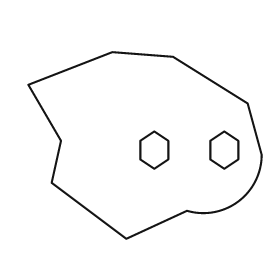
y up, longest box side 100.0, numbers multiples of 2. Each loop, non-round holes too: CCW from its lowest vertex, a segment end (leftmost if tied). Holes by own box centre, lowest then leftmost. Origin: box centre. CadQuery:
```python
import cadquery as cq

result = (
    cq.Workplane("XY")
    .moveTo(-8.0, -40.0)
    .lineTo(18.0, -28.0)
    .threePointArc((40.0, -24.0), (50.0, -4.0))
    .lineTo(44.0, 18.0)
    .lineTo(12.0, 38.0)
    .lineTo(-14.0, 40.0)
    .lineTo(-50.0, 26.0)
    .lineTo(-36.0, 2.0)
    .lineTo(-40.0, -16.0)
    .close()
    .moveTo(4.0, -10.0)
    .lineTo(10.0, -6.0)
    .lineTo(10.0, 2.0)
    .lineTo(4.0, 6.0)
    .lineTo(-2.0, 2.0)
    .lineTo(-2.0, -6.0)
    .close()
    .moveTo(34.0, -10.0)
    .lineTo(40.0, -6.0)
    .lineTo(40.0, 2.0)
    .lineTo(34.0, 6.0)
    .lineTo(28.0, 2.0)
    .lineTo(28.0, -6.0)
    .close()
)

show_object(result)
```